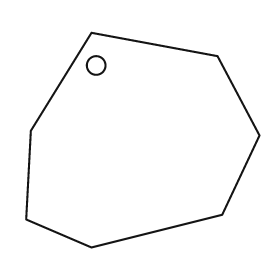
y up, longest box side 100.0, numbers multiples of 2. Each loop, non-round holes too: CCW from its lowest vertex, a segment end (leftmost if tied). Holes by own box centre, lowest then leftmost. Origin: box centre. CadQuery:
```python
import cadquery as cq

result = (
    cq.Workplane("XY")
    .moveTo(-22.0, -46.0)
    .lineTo(34.0, -32.0)
    .lineTo(50.0, 2.0)
    .lineTo(32.0, 36.0)
    .lineTo(-22.0, 46.0)
    .lineTo(-48.0, 4.0)
    .lineTo(-50.0, -34.0)
    .close()
    .moveTo(-20.0, 32.0)
    .circle(4.0)
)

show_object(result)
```